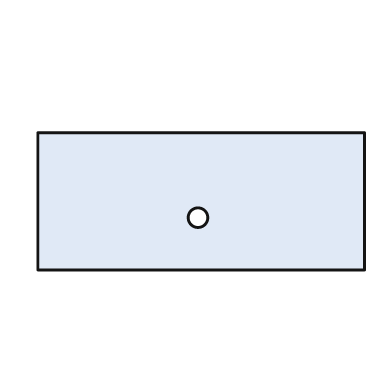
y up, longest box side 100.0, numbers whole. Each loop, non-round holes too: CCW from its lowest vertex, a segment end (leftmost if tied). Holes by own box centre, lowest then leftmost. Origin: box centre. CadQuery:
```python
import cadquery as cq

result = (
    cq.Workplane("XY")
    .moveTo(-50.0, -21.0)
    .lineTo(50.0, -21.0)
    .lineTo(50.0, 21.0)
    .lineTo(-50.0, 21.0)
    .close()
    .moveTo(-1.0, -5.0)
    .circle(3.0)
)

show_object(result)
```